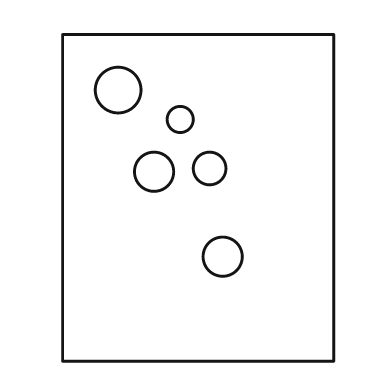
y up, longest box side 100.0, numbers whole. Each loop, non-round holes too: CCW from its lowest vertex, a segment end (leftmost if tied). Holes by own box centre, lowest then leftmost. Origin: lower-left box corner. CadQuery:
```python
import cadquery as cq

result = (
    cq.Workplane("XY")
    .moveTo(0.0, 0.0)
    .lineTo(83.0, 0.0)
    .lineTo(83.0, 100.0)
    .lineTo(0.0, 100.0)
    .close()
    .moveTo(49.0, 32.0)
    .circle(6.0)
    .moveTo(28.0, 58.0)
    .circle(6.0)
    .moveTo(45.0, 59.0)
    .circle(5.0)
    .moveTo(36.0, 74.0)
    .circle(4.0)
    .moveTo(17.0, 83.0)
    .circle(7.0)
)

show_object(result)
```